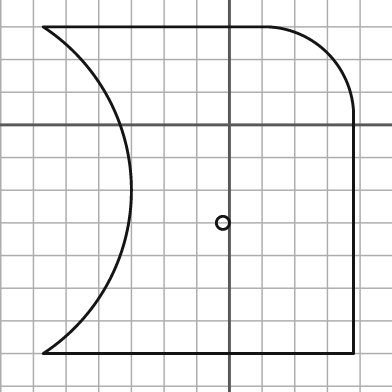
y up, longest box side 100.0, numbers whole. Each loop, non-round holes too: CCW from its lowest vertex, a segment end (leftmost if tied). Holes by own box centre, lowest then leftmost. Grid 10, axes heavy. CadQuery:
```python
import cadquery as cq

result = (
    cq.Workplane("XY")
    .moveTo(-57.0, -70.0)
    .lineTo(38.0, -70.0)
    .lineTo(38.0, 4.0)
    .threePointArc((30.0, 22.0), (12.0, 30.0))
    .lineTo(-57.0, 30.0)
    .threePointArc((-30.0, -20.0), (-57.0, -70.0))
    .close()
    .moveTo(-2.0, -30.0)
    .circle(2.0)
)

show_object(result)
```